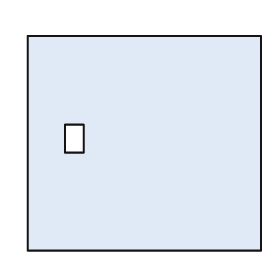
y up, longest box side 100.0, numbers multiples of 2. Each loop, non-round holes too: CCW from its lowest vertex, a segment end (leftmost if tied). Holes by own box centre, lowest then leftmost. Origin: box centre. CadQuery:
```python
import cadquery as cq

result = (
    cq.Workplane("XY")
    .moveTo(-50.0, -46.0)
    .lineTo(50.0, -46.0)
    .lineTo(50.0, 46.0)
    .lineTo(-50.0, 46.0)
    .close()
    .moveTo(-34.0, -4.0)
    .lineTo(-26.0, -4.0)
    .lineTo(-26.0, 8.0)
    .lineTo(-34.0, 8.0)
    .close()
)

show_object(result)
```